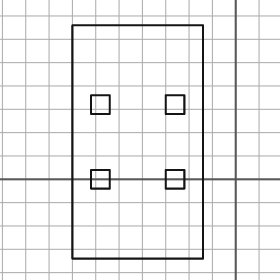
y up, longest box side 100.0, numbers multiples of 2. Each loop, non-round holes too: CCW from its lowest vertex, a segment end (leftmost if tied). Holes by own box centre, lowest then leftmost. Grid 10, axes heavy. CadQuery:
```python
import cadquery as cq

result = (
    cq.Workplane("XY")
    .moveTo(-70.0, -34.0)
    .lineTo(-14.0, -34.0)
    .lineTo(-14.0, 66.0)
    .lineTo(-70.0, 66.0)
    .close()
    .moveTo(-62.0, -4.0)
    .lineTo(-54.0, -4.0)
    .lineTo(-54.0, 4.0)
    .lineTo(-62.0, 4.0)
    .close()
    .moveTo(-30.0, -4.0)
    .lineTo(-22.0, -4.0)
    .lineTo(-22.0, 4.0)
    .lineTo(-30.0, 4.0)
    .close()
    .moveTo(-62.0, 28.0)
    .lineTo(-54.0, 28.0)
    .lineTo(-54.0, 36.0)
    .lineTo(-62.0, 36.0)
    .close()
    .moveTo(-30.0, 28.0)
    .lineTo(-22.0, 28.0)
    .lineTo(-22.0, 36.0)
    .lineTo(-30.0, 36.0)
    .close()
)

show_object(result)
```